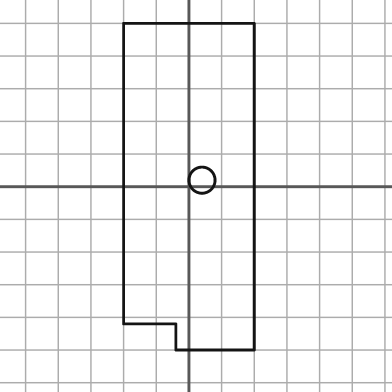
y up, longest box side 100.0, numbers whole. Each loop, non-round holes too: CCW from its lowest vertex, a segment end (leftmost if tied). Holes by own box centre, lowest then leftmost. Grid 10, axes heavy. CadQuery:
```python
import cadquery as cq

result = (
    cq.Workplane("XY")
    .moveTo(-4.0, -50.0)
    .lineTo(20.0, -50.0)
    .lineTo(20.0, 50.0)
    .lineTo(-20.0, 50.0)
    .lineTo(-20.0, -42.0)
    .lineTo(-4.0, -42.0)
    .close()
    .moveTo(4.0, 2.0)
    .circle(4.0)
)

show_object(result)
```